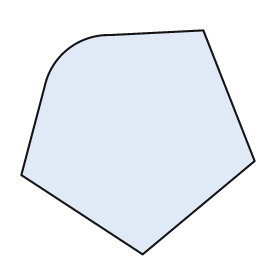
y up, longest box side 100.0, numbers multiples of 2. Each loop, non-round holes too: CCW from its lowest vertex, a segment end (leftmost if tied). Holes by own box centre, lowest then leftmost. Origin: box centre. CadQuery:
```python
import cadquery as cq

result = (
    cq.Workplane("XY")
    .moveTo(2.0, -48.0)
    .lineTo(50.0, -8.0)
    .lineTo(28.0, 48.0)
    .lineTo(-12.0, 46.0)
    .threePointArc((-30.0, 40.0), (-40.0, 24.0))
    .lineTo(-50.0, -14.0)
    .close()
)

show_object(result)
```